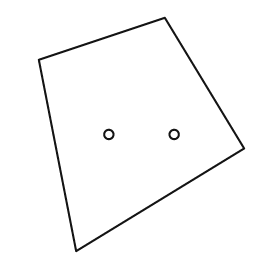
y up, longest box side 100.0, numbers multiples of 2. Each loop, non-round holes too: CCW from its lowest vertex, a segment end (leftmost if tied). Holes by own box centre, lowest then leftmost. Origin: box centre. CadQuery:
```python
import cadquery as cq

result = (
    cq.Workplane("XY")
    .moveTo(-28.0, -50.0)
    .lineTo(44.0, -6.0)
    .lineTo(10.0, 50.0)
    .lineTo(-44.0, 32.0)
    .close()
    .moveTo(-14.0, 0.0)
    .circle(2.0)
    .moveTo(14.0, 0.0)
    .circle(2.0)
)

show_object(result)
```